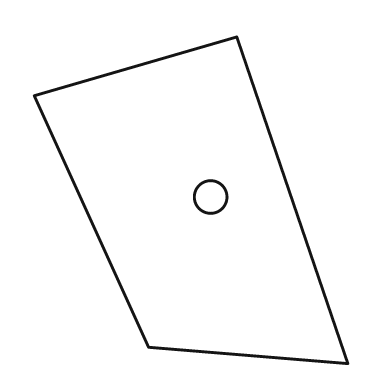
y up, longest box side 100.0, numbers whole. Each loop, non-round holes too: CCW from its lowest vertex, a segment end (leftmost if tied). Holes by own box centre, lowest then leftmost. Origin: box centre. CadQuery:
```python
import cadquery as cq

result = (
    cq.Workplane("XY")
    .moveTo(48.0, -50.0)
    .lineTo(14.0, 50.0)
    .lineTo(-48.0, 32.0)
    .lineTo(-13.0, -45.0)
    .close()
    .moveTo(6.0, 1.0)
    .circle(5.0)
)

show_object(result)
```